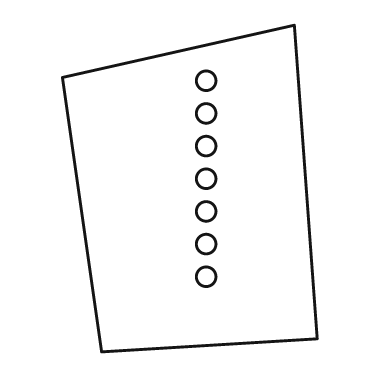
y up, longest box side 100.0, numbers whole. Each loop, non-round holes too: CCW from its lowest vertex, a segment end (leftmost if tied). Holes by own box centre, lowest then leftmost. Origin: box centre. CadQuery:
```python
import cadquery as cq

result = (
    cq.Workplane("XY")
    .moveTo(-27.0, -50.0)
    .lineTo(39.0, -46.0)
    .lineTo(32.0, 50.0)
    .lineTo(-39.0, 34.0)
    .close()
    .moveTo(5.0, -27.0)
    .circle(3.0)
    .moveTo(5.0, -17.0)
    .circle(3.0)
    .moveTo(5.0, -7.0)
    .circle(3.0)
    .moveTo(5.0, 3.0)
    .circle(3.0)
    .moveTo(5.0, 13.0)
    .circle(3.0)
    .moveTo(5.0, 23.0)
    .circle(3.0)
    .moveTo(5.0, 33.0)
    .circle(3.0)
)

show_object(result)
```